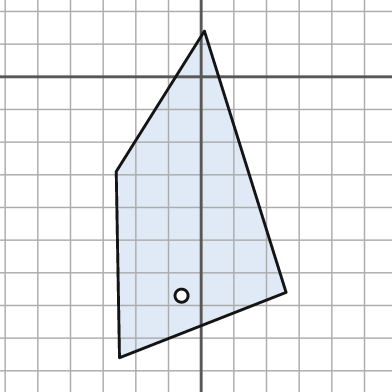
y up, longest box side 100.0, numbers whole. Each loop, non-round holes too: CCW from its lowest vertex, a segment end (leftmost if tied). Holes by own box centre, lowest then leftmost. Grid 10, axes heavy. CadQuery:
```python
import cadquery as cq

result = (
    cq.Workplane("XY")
    .moveTo(-25.0, -86.0)
    .lineTo(26.0, -66.0)
    .lineTo(1.0, 14.0)
    .lineTo(-26.0, -29.0)
    .close()
    .moveTo(-6.0, -67.0)
    .circle(2.0)
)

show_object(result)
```